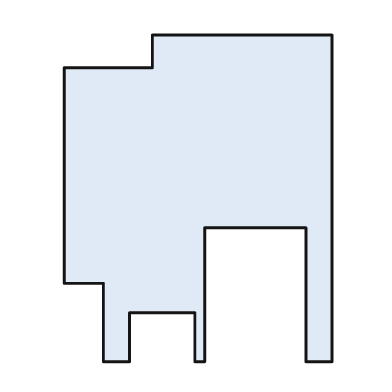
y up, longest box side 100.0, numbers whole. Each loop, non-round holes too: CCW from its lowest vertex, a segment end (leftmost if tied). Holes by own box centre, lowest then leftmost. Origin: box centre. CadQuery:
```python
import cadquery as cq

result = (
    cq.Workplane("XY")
    .moveTo(-29.0, -50.0)
    .lineTo(-21.0, -50.0)
    .lineTo(-21.0, -35.0)
    .lineTo(-1.0, -35.0)
    .lineTo(-1.0, -50.0)
    .lineTo(2.0, -50.0)
    .lineTo(2.0, -9.0)
    .lineTo(33.0, -9.0)
    .lineTo(33.0, -50.0)
    .lineTo(41.0, -50.0)
    .lineTo(41.0, 50.0)
    .lineTo(-14.0, 50.0)
    .lineTo(-14.0, 40.0)
    .lineTo(-41.0, 40.0)
    .lineTo(-41.0, -26.0)
    .lineTo(-29.0, -26.0)
    .close()
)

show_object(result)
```